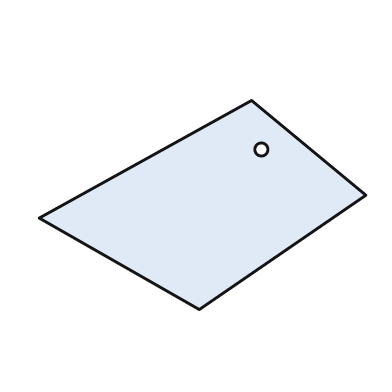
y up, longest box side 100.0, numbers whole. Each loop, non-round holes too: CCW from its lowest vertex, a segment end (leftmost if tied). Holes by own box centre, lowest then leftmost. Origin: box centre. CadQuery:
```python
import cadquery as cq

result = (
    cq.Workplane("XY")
    .moveTo(-1.0, -32.0)
    .lineTo(50.0, 3.0)
    .lineTo(15.0, 32.0)
    .lineTo(-50.0, -4.0)
    .close()
    .moveTo(18.0, 17.0)
    .circle(2.0)
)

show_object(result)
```